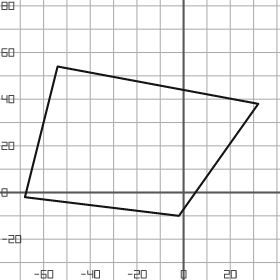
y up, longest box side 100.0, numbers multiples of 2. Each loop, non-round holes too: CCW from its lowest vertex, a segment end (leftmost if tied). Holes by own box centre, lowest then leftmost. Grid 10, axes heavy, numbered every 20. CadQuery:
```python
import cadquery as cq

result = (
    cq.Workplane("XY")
    .moveTo(-2.0, -10.0)
    .lineTo(32.0, 38.0)
    .lineTo(-54.0, 54.0)
    .lineTo(-68.0, -2.0)
    .close()
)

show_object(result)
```